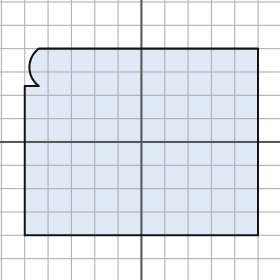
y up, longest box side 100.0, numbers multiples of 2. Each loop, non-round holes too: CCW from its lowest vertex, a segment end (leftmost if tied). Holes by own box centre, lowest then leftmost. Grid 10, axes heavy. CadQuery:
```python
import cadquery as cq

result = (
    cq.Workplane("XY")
    .moveTo(-50.0, -40.0)
    .lineTo(50.0, -40.0)
    .lineTo(50.0, 40.0)
    .lineTo(-44.0, 40.0)
    .threePointArc((-48.0, 32.0), (-44.0, 24.0))
    .lineTo(-50.0, 24.0)
    .close()
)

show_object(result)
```